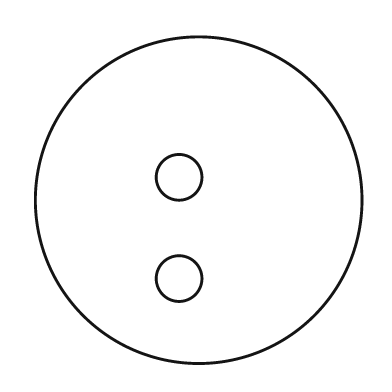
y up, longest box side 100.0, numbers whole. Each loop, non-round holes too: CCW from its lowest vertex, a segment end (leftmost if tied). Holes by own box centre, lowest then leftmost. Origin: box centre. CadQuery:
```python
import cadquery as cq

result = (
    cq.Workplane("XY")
    .moveTo(0.0, 0.0)
    .circle(50.0)
    .moveTo(-6.0, -24.0)
    .circle(7.0)
    .moveTo(-6.0, 7.0)
    .circle(7.0)
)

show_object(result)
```